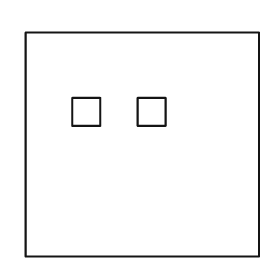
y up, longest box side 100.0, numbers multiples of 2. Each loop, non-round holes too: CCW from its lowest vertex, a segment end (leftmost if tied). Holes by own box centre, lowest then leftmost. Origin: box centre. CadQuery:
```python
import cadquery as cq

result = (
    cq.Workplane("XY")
    .moveTo(-50.0, -48.0)
    .lineTo(50.0, -48.0)
    .lineTo(50.0, 48.0)
    .lineTo(-50.0, 48.0)
    .close()
    .moveTo(-30.0, 8.0)
    .lineTo(-18.0, 8.0)
    .lineTo(-18.0, 20.0)
    .lineTo(-30.0, 20.0)
    .close()
    .moveTo(-2.0, 8.0)
    .lineTo(10.0, 8.0)
    .lineTo(10.0, 20.0)
    .lineTo(-2.0, 20.0)
    .close()
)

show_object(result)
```